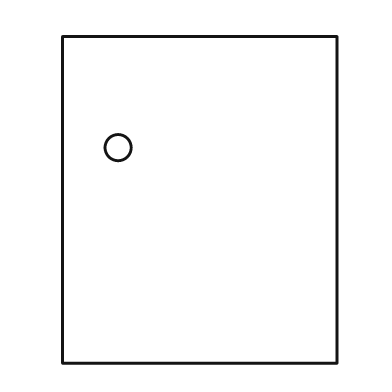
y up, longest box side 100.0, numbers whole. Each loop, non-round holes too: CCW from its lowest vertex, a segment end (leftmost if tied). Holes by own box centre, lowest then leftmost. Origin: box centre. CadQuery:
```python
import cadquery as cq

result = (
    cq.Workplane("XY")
    .moveTo(-42.0, -50.0)
    .lineTo(42.0, -50.0)
    .lineTo(42.0, 50.0)
    .lineTo(-42.0, 50.0)
    .close()
    .moveTo(-25.0, 16.0)
    .circle(4.0)
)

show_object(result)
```